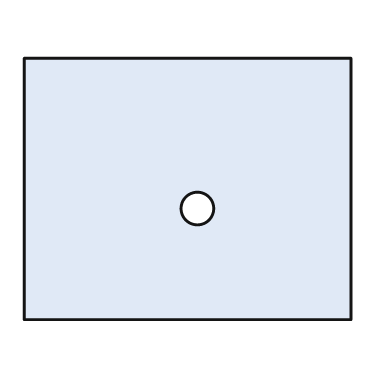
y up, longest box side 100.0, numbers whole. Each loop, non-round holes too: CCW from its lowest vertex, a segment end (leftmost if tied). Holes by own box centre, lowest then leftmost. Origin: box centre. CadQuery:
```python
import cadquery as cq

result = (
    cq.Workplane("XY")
    .moveTo(-50.0, -40.0)
    .lineTo(50.0, -40.0)
    .lineTo(50.0, 40.0)
    .lineTo(-50.0, 40.0)
    .close()
    .moveTo(3.0, -6.0)
    .circle(5.0)
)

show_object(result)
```